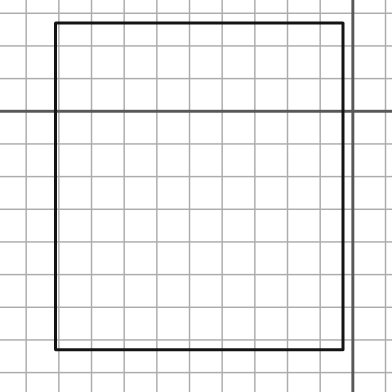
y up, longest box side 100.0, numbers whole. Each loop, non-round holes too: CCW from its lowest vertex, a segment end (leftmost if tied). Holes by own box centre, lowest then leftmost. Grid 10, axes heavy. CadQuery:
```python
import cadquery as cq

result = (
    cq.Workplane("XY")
    .moveTo(-91.0, -73.0)
    .lineTo(-3.0, -73.0)
    .lineTo(-3.0, 27.0)
    .lineTo(-91.0, 27.0)
    .close()
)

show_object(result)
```